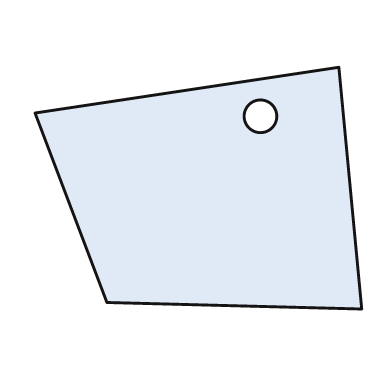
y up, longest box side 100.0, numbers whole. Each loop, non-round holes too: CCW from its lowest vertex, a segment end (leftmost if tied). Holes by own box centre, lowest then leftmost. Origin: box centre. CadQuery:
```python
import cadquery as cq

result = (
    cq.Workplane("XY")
    .moveTo(50.0, -37.0)
    .lineTo(43.0, 37.0)
    .lineTo(-50.0, 23.0)
    .lineTo(-28.0, -35.0)
    .close()
    .moveTo(19.0, 22.0)
    .circle(5.0)
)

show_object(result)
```